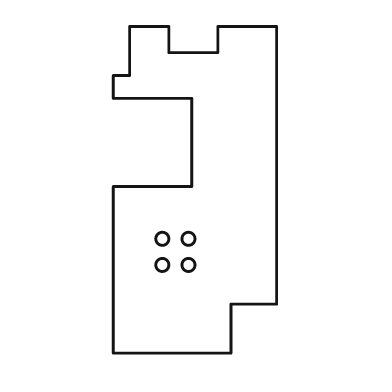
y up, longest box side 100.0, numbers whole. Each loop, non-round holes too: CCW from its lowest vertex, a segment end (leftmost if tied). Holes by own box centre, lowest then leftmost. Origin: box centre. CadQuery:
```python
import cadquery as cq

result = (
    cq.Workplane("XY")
    .moveTo(-25.0, -50.0)
    .lineTo(11.0, -50.0)
    .lineTo(11.0, -35.0)
    .lineTo(25.0, -35.0)
    .lineTo(25.0, 50.0)
    .lineTo(7.0, 50.0)
    .lineTo(7.0, 42.0)
    .lineTo(-8.0, 42.0)
    .lineTo(-8.0, 50.0)
    .lineTo(-20.0, 50.0)
    .lineTo(-20.0, 35.0)
    .lineTo(-25.0, 35.0)
    .lineTo(-25.0, 28.0)
    .lineTo(-1.0, 28.0)
    .lineTo(-1.0, 1.0)
    .lineTo(-25.0, 1.0)
    .close()
    .moveTo(-10.0, -23.0)
    .circle(2.0)
    .moveTo(-2.0, -23.0)
    .circle(2.0)
    .moveTo(-10.0, -15.0)
    .circle(2.0)
    .moveTo(-2.0, -15.0)
    .circle(2.0)
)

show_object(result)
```